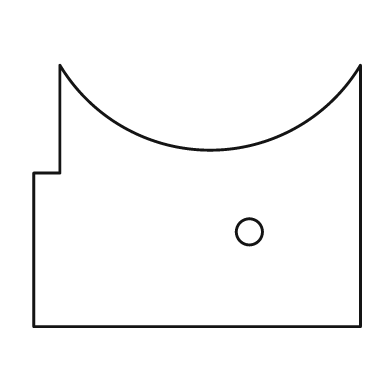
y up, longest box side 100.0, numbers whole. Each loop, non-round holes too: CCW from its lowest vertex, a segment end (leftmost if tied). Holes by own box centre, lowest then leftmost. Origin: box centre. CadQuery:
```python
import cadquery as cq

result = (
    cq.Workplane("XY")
    .moveTo(-50.0, -40.0)
    .lineTo(50.0, -40.0)
    .lineTo(50.0, 40.0)
    .threePointArc((4.0, 14.0), (-42.0, 40.0))
    .lineTo(-42.0, 7.0)
    .lineTo(-50.0, 7.0)
    .close()
    .moveTo(16.0, -11.0)
    .circle(4.0)
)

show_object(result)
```